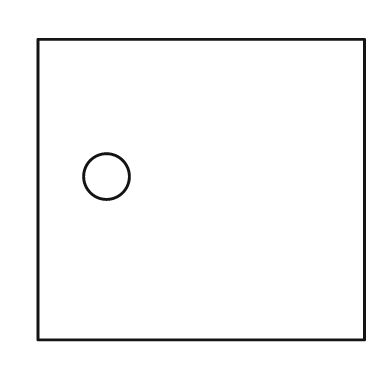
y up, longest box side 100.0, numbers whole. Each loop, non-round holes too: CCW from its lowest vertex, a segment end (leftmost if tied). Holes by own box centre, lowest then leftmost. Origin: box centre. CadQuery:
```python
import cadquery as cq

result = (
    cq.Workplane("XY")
    .moveTo(-50.0, -46.0)
    .lineTo(50.0, -46.0)
    .lineTo(50.0, 46.0)
    .lineTo(-50.0, 46.0)
    .close()
    .moveTo(-29.0, 4.0)
    .circle(7.0)
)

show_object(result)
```